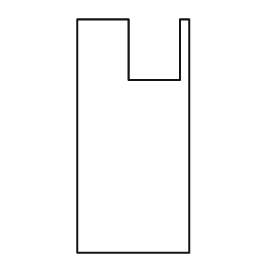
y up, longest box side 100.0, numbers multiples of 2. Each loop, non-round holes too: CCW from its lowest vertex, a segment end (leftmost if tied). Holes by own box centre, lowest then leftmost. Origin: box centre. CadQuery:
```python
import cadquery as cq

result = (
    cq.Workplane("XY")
    .moveTo(-24.0, -50.0)
    .lineTo(24.0, -50.0)
    .lineTo(24.0, 50.0)
    .lineTo(20.0, 50.0)
    .lineTo(20.0, 24.0)
    .lineTo(-2.0, 24.0)
    .lineTo(-2.0, 50.0)
    .lineTo(-24.0, 50.0)
    .close()
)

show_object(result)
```